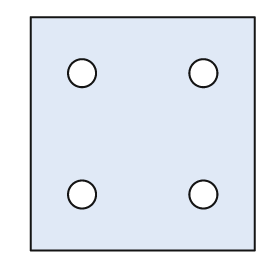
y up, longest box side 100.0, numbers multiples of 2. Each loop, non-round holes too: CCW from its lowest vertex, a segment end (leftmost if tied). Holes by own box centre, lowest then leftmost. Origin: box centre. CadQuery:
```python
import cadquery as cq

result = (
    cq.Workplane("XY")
    .moveTo(-48.0, -50.0)
    .lineTo(48.0, -50.0)
    .lineTo(48.0, 50.0)
    .lineTo(-48.0, 50.0)
    .close()
    .moveTo(-26.0, -26.0)
    .circle(6.0)
    .moveTo(26.0, -26.0)
    .circle(6.0)
    .moveTo(-26.0, 26.0)
    .circle(6.0)
    .moveTo(26.0, 26.0)
    .circle(6.0)
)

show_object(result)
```